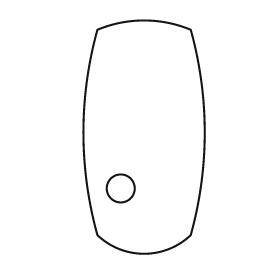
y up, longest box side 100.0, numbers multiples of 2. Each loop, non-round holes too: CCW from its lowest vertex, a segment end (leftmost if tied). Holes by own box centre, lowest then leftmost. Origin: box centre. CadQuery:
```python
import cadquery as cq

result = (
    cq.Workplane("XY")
    .moveTo(-20.0, -42.0)
    .threePointArc((0.0, -50.0), (20.0, -42.0))
    .threePointArc((26.0, 2.0), (20.0, 46.0))
    .threePointArc((0.0, 50.0), (-20.0, 46.0))
    .threePointArc((-26.0, 2.0), (-20.0, -42.0))
    .close()
    .moveTo(-10.0, -22.0)
    .circle(6.0)
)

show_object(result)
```